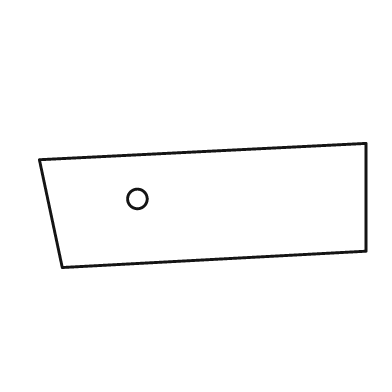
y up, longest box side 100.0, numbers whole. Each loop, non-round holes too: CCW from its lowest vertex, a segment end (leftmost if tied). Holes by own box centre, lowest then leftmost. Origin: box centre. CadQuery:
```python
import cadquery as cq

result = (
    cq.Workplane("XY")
    .moveTo(-43.0, -19.0)
    .lineTo(50.0, -14.0)
    .lineTo(50.0, 19.0)
    .lineTo(-50.0, 14.0)
    .close()
    .moveTo(-20.0, 2.0)
    .circle(3.0)
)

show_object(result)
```